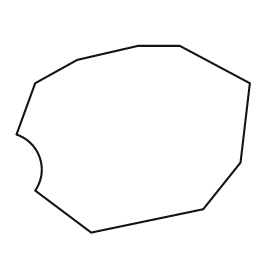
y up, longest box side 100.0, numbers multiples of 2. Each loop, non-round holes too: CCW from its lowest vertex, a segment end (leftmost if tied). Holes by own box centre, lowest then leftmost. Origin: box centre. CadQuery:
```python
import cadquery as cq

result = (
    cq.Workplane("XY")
    .moveTo(-18.0, -40.0)
    .lineTo(30.0, -30.0)
    .lineTo(46.0, -10.0)
    .lineTo(50.0, 24.0)
    .lineTo(20.0, 40.0)
    .lineTo(2.0, 40.0)
    .lineTo(-24.0, 34.0)
    .lineTo(-42.0, 24.0)
    .lineTo(-50.0, 2.0)
    .threePointArc((-40.0, -8.0), (-42.0, -22.0))
    .close()
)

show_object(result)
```